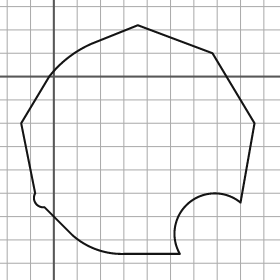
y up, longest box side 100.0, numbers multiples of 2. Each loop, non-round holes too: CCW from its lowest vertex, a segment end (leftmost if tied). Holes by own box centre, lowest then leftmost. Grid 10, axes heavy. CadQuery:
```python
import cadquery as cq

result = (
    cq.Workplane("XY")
    .moveTo(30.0, -76.0)
    .lineTo(54.0, -76.0)
    .threePointArc((58.0, -54.0), (80.0, -54.0))
    .lineTo(86.0, -20.0)
    .lineTo(68.0, 10.0)
    .lineTo(36.0, 22.0)
    .lineTo(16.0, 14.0)
    .threePointArc((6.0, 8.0), (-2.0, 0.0))
    .lineTo(-14.0, -20.0)
    .lineTo(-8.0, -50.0)
    .threePointArc((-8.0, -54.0), (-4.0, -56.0))
    .lineTo(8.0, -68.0)
    .threePointArc((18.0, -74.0), (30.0, -76.0))
    .close()
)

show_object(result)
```